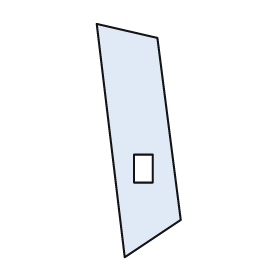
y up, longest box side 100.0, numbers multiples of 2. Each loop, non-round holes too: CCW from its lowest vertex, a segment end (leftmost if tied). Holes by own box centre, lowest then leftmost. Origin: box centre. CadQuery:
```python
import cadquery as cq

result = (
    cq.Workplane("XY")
    .moveTo(-6.0, -50.0)
    .lineTo(18.0, -34.0)
    .lineTo(8.0, 44.0)
    .lineTo(-18.0, 50.0)
    .close()
    .moveTo(-2.0, -18.0)
    .lineTo(6.0, -18.0)
    .lineTo(6.0, -6.0)
    .lineTo(-2.0, -6.0)
    .close()
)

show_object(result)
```